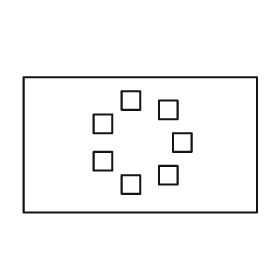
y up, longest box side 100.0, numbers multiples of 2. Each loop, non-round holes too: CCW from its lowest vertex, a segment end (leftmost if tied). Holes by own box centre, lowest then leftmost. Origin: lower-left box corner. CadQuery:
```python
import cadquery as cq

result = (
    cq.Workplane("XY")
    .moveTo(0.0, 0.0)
    .lineTo(100.0, 0.0)
    .lineTo(100.0, 58.0)
    .lineTo(0.0, 58.0)
    .close()
    .moveTo(42.0, 8.0)
    .lineTo(50.0, 8.0)
    .lineTo(50.0, 16.0)
    .lineTo(42.0, 16.0)
    .close()
    .moveTo(58.0, 12.0)
    .lineTo(66.0, 12.0)
    .lineTo(66.0, 20.0)
    .lineTo(58.0, 20.0)
    .close()
    .moveTo(30.0, 18.0)
    .lineTo(38.0, 18.0)
    .lineTo(38.0, 26.0)
    .lineTo(30.0, 26.0)
    .close()
    .moveTo(64.0, 26.0)
    .lineTo(72.0, 26.0)
    .lineTo(72.0, 34.0)
    .lineTo(64.0, 34.0)
    .close()
    .moveTo(30.0, 34.0)
    .lineTo(38.0, 34.0)
    .lineTo(38.0, 42.0)
    .lineTo(30.0, 42.0)
    .close()
    .moveTo(58.0, 40.0)
    .lineTo(66.0, 40.0)
    .lineTo(66.0, 48.0)
    .lineTo(58.0, 48.0)
    .close()
    .moveTo(42.0, 44.0)
    .lineTo(50.0, 44.0)
    .lineTo(50.0, 52.0)
    .lineTo(42.0, 52.0)
    .close()
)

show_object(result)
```